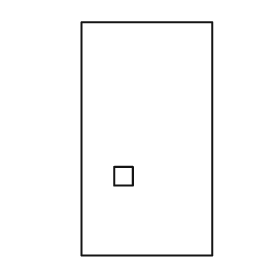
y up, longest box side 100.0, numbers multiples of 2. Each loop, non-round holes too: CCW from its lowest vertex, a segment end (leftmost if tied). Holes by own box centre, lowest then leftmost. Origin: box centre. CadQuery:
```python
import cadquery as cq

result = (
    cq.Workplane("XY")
    .moveTo(-28.0, -50.0)
    .lineTo(28.0, -50.0)
    .lineTo(28.0, 50.0)
    .lineTo(-28.0, 50.0)
    .close()
    .moveTo(-14.0, -20.0)
    .lineTo(-6.0, -20.0)
    .lineTo(-6.0, -12.0)
    .lineTo(-14.0, -12.0)
    .close()
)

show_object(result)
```